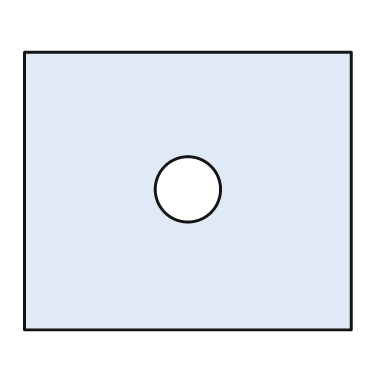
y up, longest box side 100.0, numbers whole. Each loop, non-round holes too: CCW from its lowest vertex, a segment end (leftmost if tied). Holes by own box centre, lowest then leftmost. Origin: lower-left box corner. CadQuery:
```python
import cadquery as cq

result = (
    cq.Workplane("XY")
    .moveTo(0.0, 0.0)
    .lineTo(100.0, 0.0)
    .lineTo(100.0, 85.0)
    .lineTo(0.0, 85.0)
    .close()
    .moveTo(50.0, 43.0)
    .circle(10.0)
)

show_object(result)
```